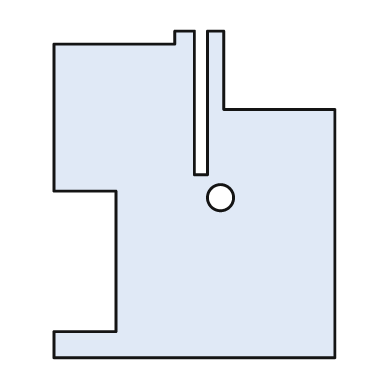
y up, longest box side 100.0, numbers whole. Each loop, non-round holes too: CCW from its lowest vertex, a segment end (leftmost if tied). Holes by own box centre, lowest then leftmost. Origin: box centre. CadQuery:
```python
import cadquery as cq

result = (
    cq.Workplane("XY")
    .moveTo(-43.0, -50.0)
    .lineTo(43.0, -50.0)
    .lineTo(43.0, 26.0)
    .lineTo(9.0, 26.0)
    .lineTo(9.0, 50.0)
    .lineTo(4.0, 50.0)
    .lineTo(4.0, 6.0)
    .lineTo(0.0, 6.0)
    .lineTo(0.0, 50.0)
    .lineTo(-6.0, 50.0)
    .lineTo(-6.0, 46.0)
    .lineTo(-43.0, 46.0)
    .lineTo(-43.0, 1.0)
    .lineTo(-24.0, 1.0)
    .lineTo(-24.0, -42.0)
    .lineTo(-43.0, -42.0)
    .close()
    .moveTo(8.0, -1.0)
    .circle(4.0)
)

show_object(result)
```